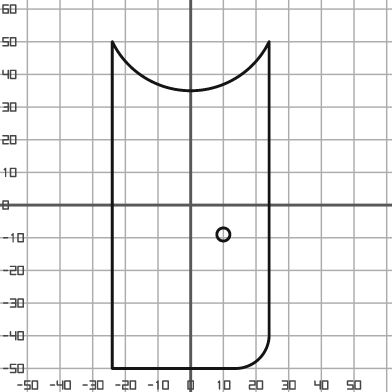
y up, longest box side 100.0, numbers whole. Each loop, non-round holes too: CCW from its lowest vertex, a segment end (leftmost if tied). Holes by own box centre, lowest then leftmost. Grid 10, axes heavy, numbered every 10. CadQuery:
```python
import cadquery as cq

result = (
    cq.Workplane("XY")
    .moveTo(-24.0, -50.0)
    .lineTo(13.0, -50.0)
    .threePointArc((21.0, -47.0), (24.0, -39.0))
    .lineTo(24.0, 50.0)
    .threePointArc((0.0, 35.0), (-24.0, 50.0))
    .close()
    .moveTo(10.0, -9.0)
    .circle(2.0)
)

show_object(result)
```